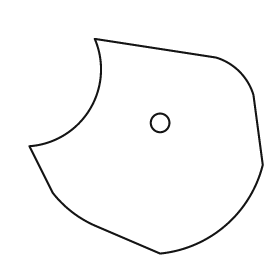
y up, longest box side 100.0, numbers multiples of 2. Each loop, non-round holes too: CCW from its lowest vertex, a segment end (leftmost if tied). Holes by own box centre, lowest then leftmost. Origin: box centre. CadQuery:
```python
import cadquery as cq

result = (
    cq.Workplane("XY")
    .moveTo(6.0, -46.0)
    .threePointArc((34.0, -34.0), (50.0, -8.0))
    .lineTo(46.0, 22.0)
    .threePointArc((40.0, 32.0), (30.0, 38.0))
    .lineTo(-22.0, 46.0)
    .threePointArc((-24.0, 16.0), (-50.0, 0.0))
    .lineTo(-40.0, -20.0)
    .threePointArc((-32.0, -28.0), (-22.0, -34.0))
    .close()
    .moveTo(6.0, 10.0)
    .circle(4.0)
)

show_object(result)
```